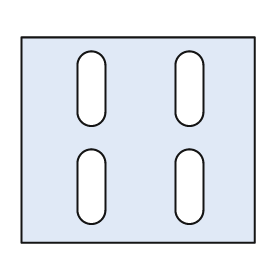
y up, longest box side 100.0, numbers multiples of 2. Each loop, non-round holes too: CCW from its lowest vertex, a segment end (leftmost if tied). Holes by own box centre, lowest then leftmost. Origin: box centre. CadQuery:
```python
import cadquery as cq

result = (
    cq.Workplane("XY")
    .moveTo(-50.0, -44.0)
    .lineTo(50.0, -44.0)
    .lineTo(50.0, 44.0)
    .lineTo(-50.0, 44.0)
    .close()
    .moveTo(-26.0, -30.0)
    .threePointArc((-20.0, -36.0), (-14.0, -30.0))
    .lineTo(-14.0, -10.0)
    .threePointArc((-20.0, -4.0), (-26.0, -10.0))
    .close()
    .moveTo(16.0, -30.0)
    .threePointArc((22.0, -36.0), (28.0, -30.0))
    .lineTo(28.0, -10.0)
    .threePointArc((22.0, -4.0), (16.0, -10.0))
    .close()
    .moveTo(-26.0, 12.0)
    .threePointArc((-20.0, 6.0), (-14.0, 12.0))
    .lineTo(-14.0, 32.0)
    .threePointArc((-20.0, 38.0), (-26.0, 32.0))
    .close()
    .moveTo(16.0, 12.0)
    .threePointArc((22.0, 6.0), (28.0, 12.0))
    .lineTo(28.0, 32.0)
    .threePointArc((22.0, 38.0), (16.0, 32.0))
    .close()
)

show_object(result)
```